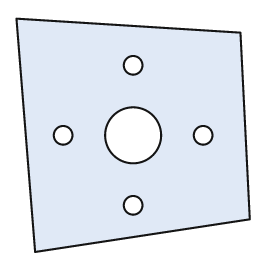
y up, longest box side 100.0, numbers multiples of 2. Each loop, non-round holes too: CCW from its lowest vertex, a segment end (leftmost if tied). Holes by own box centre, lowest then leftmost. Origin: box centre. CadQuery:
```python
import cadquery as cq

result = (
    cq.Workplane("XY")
    .moveTo(-42.0, -50.0)
    .lineTo(50.0, -36.0)
    .lineTo(46.0, 44.0)
    .lineTo(-50.0, 50.0)
    .close()
    .moveTo(0.0, -30.0)
    .circle(4.0)
    .moveTo(-30.0, 0.0)
    .circle(4.0)
    .moveTo(0.0, 0.0)
    .circle(12.0)
    .moveTo(30.0, 0.0)
    .circle(4.0)
    .moveTo(0.0, 30.0)
    .circle(4.0)
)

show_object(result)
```